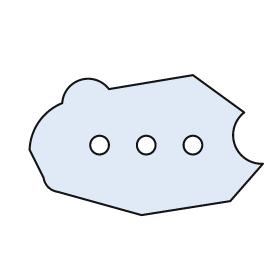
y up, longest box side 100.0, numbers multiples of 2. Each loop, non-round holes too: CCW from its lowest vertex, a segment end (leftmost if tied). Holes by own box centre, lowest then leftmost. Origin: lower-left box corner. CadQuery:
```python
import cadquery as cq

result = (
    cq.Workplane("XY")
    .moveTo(48.0, 0.0)
    .lineTo(86.0, 6.0)
    .lineTo(100.0, 22.0)
    .threePointArc((88.0, 30.0), (92.0, 44.0))
    .lineTo(70.0, 60.0)
    .lineTo(34.0, 54.0)
    .threePointArc((22.0, 58.0), (14.0, 48.0))
    .threePointArc((4.0, 40.0), (0.0, 28.0))
    .lineTo(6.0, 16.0)
    .threePointArc((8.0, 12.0), (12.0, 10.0))
    .close()
    .moveTo(30.0, 30.0)
    .circle(4.0)
    .moveTo(50.0, 30.0)
    .circle(4.0)
    .moveTo(70.0, 30.0)
    .circle(4.0)
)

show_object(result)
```